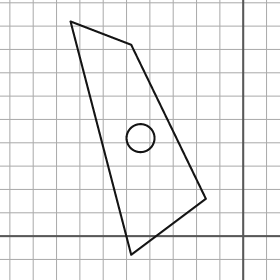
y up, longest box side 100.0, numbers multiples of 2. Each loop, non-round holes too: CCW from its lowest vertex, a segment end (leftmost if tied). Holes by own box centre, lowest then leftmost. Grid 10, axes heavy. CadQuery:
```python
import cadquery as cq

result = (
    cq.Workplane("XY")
    .moveTo(-48.0, -8.0)
    .lineTo(-16.0, 16.0)
    .lineTo(-48.0, 82.0)
    .lineTo(-74.0, 92.0)
    .close()
    .moveTo(-44.0, 42.0)
    .circle(6.0)
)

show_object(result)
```